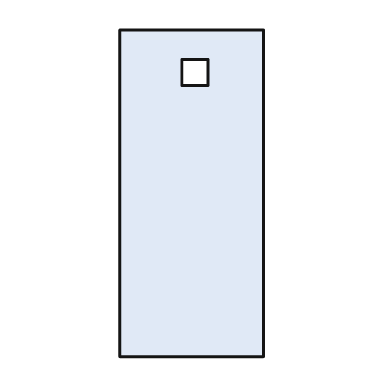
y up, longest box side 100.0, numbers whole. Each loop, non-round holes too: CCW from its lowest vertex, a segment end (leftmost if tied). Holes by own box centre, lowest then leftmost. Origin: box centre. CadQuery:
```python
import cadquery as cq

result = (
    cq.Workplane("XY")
    .moveTo(-22.0, -50.0)
    .lineTo(22.0, -50.0)
    .lineTo(22.0, 50.0)
    .lineTo(-22.0, 50.0)
    .close()
    .moveTo(-3.0, 33.0)
    .lineTo(5.0, 33.0)
    .lineTo(5.0, 41.0)
    .lineTo(-3.0, 41.0)
    .close()
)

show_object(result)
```